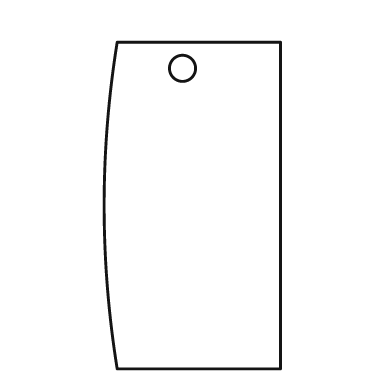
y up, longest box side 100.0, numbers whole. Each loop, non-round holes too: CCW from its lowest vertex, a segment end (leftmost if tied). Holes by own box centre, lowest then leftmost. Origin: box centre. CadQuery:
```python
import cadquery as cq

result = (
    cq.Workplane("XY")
    .moveTo(-23.0, -50.0)
    .lineTo(27.0, -50.0)
    .lineTo(27.0, 50.0)
    .lineTo(-23.0, 50.0)
    .threePointArc((-27.0, 0.0), (-23.0, -50.0))
    .close()
    .moveTo(-3.0, 42.0)
    .circle(4.0)
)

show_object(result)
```